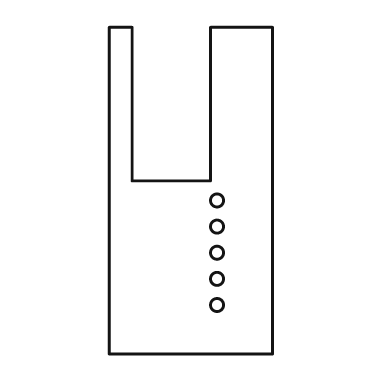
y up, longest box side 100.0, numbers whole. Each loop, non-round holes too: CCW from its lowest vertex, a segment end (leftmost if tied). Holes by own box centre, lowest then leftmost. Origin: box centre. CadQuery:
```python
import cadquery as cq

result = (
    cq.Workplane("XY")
    .moveTo(-25.0, -50.0)
    .lineTo(25.0, -50.0)
    .lineTo(25.0, 50.0)
    .lineTo(6.0, 50.0)
    .lineTo(6.0, 3.0)
    .lineTo(-18.0, 3.0)
    .lineTo(-18.0, 50.0)
    .lineTo(-25.0, 50.0)
    .close()
    .moveTo(8.0, -35.0)
    .circle(2.0)
    .moveTo(8.0, -27.0)
    .circle(2.0)
    .moveTo(8.0, -19.0)
    .circle(2.0)
    .moveTo(8.0, -11.0)
    .circle(2.0)
    .moveTo(8.0, -3.0)
    .circle(2.0)
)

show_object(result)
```